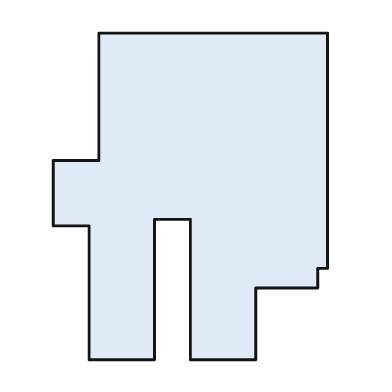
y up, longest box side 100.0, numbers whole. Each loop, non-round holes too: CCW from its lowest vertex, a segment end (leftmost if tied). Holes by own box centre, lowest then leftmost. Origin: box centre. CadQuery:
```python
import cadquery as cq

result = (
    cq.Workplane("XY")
    .moveTo(-31.0, -50.0)
    .lineTo(-11.0, -50.0)
    .lineTo(-11.0, -7.0)
    .lineTo(0.0, -7.0)
    .lineTo(0.0, -50.0)
    .lineTo(20.0, -50.0)
    .lineTo(20.0, -28.0)
    .lineTo(39.0, -28.0)
    .lineTo(39.0, -22.0)
    .lineTo(42.0, -22.0)
    .lineTo(42.0, 50.0)
    .lineTo(-28.0, 50.0)
    .lineTo(-28.0, 11.0)
    .lineTo(-42.0, 11.0)
    .lineTo(-42.0, -9.0)
    .lineTo(-31.0, -9.0)
    .close()
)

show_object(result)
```